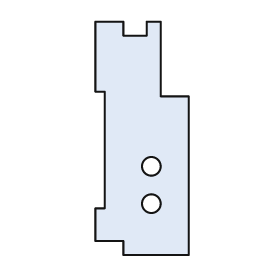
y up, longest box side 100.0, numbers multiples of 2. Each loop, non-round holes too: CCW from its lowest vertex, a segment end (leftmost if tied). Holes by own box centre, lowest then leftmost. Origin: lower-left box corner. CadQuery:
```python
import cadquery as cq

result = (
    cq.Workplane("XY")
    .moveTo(12.0, 0.0)
    .lineTo(40.0, 0.0)
    .lineTo(40.0, 68.0)
    .lineTo(28.0, 68.0)
    .lineTo(28.0, 100.0)
    .lineTo(22.0, 100.0)
    .lineTo(22.0, 94.0)
    .lineTo(12.0, 94.0)
    .lineTo(12.0, 100.0)
    .lineTo(0.0, 100.0)
    .lineTo(0.0, 70.0)
    .lineTo(4.0, 70.0)
    .lineTo(4.0, 20.0)
    .lineTo(0.0, 20.0)
    .lineTo(0.0, 6.0)
    .lineTo(12.0, 6.0)
    .close()
    .moveTo(24.0, 22.0)
    .circle(4.0)
    .moveTo(24.0, 38.0)
    .circle(4.0)
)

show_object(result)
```